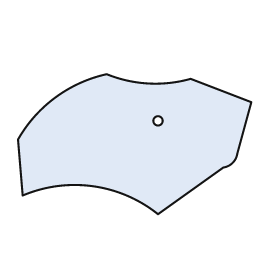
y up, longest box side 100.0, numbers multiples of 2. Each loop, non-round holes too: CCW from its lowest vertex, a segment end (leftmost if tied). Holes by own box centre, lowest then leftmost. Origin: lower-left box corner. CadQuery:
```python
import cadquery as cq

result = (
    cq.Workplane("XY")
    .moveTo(60.0, 0.0)
    .lineTo(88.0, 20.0)
    .threePointArc((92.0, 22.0), (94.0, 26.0))
    .lineTo(100.0, 48.0)
    .lineTo(74.0, 58.0)
    .threePointArc((56.0, 56.0), (38.0, 60.0))
    .threePointArc((16.0, 50.0), (0.0, 32.0))
    .lineTo(2.0, 8.0)
    .threePointArc((32.0, 12.0), (60.0, 0.0))
    .close()
    .moveTo(60.0, 40.0)
    .circle(2.0)
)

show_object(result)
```